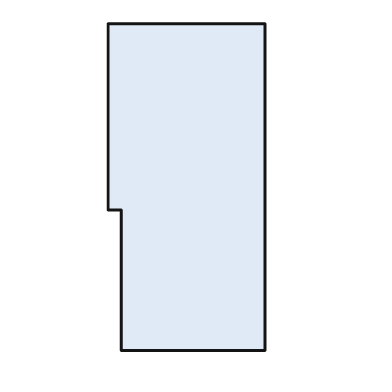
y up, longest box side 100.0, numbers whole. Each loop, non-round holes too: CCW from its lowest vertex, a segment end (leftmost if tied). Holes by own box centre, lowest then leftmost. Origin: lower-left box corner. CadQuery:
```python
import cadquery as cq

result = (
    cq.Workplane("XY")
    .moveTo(4.0, 0.0)
    .lineTo(48.0, 0.0)
    .lineTo(48.0, 100.0)
    .lineTo(0.0, 100.0)
    .lineTo(0.0, 43.0)
    .lineTo(4.0, 43.0)
    .close()
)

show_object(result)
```